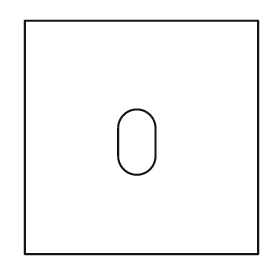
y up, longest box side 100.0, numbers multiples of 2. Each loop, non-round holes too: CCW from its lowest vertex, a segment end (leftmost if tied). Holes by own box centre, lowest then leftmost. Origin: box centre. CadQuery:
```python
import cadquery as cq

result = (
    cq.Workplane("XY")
    .moveTo(-50.0, -50.0)
    .lineTo(50.0, -50.0)
    .lineTo(50.0, 50.0)
    .lineTo(-50.0, 50.0)
    .close()
    .moveTo(-10.0, -8.0)
    .threePointArc((-2.0, -16.0), (6.0, -8.0))
    .lineTo(6.0, 4.0)
    .threePointArc((-2.0, 12.0), (-10.0, 4.0))
    .close()
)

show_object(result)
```